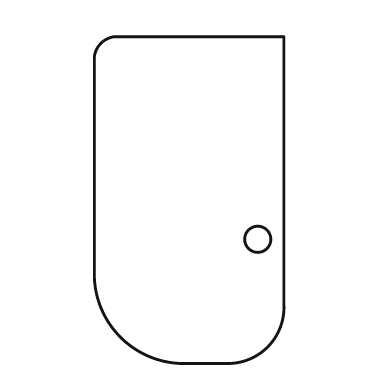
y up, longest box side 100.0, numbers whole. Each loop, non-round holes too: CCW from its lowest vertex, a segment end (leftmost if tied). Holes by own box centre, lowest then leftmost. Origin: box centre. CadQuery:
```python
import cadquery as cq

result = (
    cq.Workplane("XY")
    .moveTo(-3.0, -50.0)
    .lineTo(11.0, -50.0)
    .threePointArc((24.0, -45.0), (29.0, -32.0))
    .lineTo(29.0, 50.0)
    .lineTo(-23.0, 50.0)
    .threePointArc((-27.0, 48.0), (-29.0, 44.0))
    .lineTo(-29.0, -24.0)
    .threePointArc((-21.0, -42.0), (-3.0, -50.0))
    .close()
    .moveTo(21.0, -12.0)
    .circle(4.0)
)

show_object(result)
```